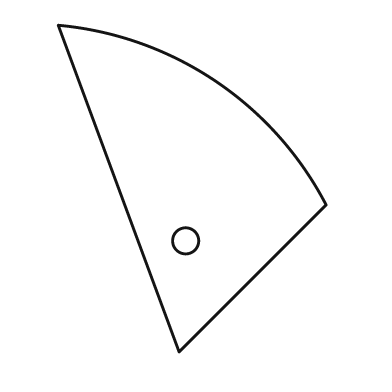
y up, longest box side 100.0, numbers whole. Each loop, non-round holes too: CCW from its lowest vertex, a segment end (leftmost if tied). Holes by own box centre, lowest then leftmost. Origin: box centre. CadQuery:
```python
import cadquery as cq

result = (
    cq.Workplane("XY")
    .moveTo(-4.0, -50.0)
    .lineTo(41.0, -5.0)
    .threePointArc((7.0, 33.0), (-41.0, 50.0))
    .close()
    .moveTo(-2.0, -16.0)
    .circle(4.0)
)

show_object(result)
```